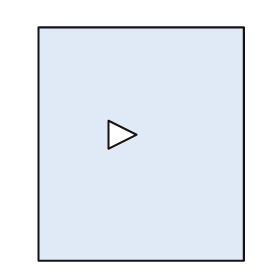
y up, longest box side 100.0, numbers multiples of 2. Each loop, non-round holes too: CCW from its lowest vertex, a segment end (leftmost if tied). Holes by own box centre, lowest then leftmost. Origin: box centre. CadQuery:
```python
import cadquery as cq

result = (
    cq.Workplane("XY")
    .moveTo(-44.0, -50.0)
    .lineTo(44.0, -50.0)
    .lineTo(44.0, 50.0)
    .lineTo(-44.0, 50.0)
    .close()
    .moveTo(-14.0, -2.0)
    .lineTo(-2.0, 4.0)
    .lineTo(-14.0, 10.0)
    .close()
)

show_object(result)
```